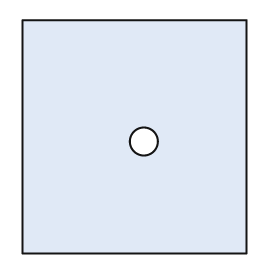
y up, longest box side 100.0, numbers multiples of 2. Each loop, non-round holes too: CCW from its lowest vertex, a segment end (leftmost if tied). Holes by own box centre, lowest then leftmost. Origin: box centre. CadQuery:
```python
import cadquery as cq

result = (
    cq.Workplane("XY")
    .moveTo(-48.0, -50.0)
    .lineTo(48.0, -50.0)
    .lineTo(48.0, 50.0)
    .lineTo(-48.0, 50.0)
    .close()
    .moveTo(4.0, -2.0)
    .circle(6.0)
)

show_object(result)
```